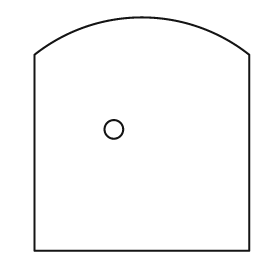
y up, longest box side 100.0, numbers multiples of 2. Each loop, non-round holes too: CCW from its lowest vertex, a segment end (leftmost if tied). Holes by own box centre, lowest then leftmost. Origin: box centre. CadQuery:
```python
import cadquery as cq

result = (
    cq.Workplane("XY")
    .moveTo(-46.0, -50.0)
    .lineTo(46.0, -50.0)
    .lineTo(46.0, 34.0)
    .threePointArc((0.0, 50.0), (-46.0, 34.0))
    .close()
    .moveTo(-12.0, 2.0)
    .circle(4.0)
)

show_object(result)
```